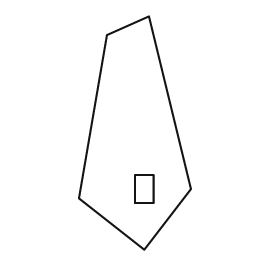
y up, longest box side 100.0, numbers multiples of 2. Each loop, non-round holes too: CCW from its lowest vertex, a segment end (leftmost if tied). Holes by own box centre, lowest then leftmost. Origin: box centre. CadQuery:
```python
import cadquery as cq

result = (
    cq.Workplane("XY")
    .moveTo(4.0, -50.0)
    .lineTo(24.0, -24.0)
    .lineTo(6.0, 50.0)
    .lineTo(-12.0, 42.0)
    .lineTo(-24.0, -28.0)
    .close()
    .moveTo(0.0, -30.0)
    .lineTo(8.0, -30.0)
    .lineTo(8.0, -18.0)
    .lineTo(0.0, -18.0)
    .close()
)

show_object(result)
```